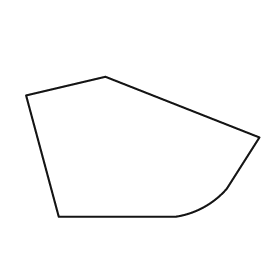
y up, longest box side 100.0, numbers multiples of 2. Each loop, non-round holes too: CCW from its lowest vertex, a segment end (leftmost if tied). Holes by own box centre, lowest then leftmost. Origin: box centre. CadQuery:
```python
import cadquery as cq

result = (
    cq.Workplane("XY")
    .moveTo(-36.0, -30.0)
    .lineTo(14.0, -30.0)
    .threePointArc((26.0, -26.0), (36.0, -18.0))
    .lineTo(50.0, 4.0)
    .lineTo(-16.0, 30.0)
    .lineTo(-50.0, 22.0)
    .close()
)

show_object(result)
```